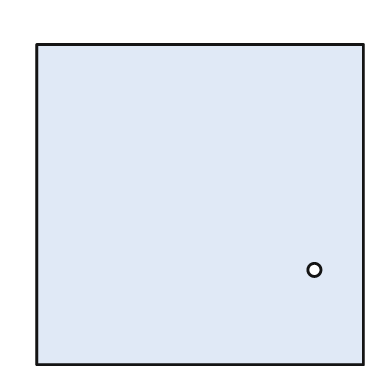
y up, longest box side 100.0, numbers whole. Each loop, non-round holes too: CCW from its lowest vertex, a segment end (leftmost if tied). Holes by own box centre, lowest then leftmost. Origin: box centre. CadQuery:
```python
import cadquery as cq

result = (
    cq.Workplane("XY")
    .moveTo(-50.0, -49.0)
    .lineTo(50.0, -49.0)
    .lineTo(50.0, 49.0)
    .lineTo(-50.0, 49.0)
    .close()
    .moveTo(35.0, -20.0)
    .circle(2.0)
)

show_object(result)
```